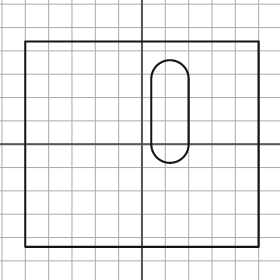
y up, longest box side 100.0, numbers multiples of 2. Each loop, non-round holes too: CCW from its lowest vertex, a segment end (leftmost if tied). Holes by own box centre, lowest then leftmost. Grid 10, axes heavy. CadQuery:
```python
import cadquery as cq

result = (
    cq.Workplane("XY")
    .moveTo(-50.0, -44.0)
    .lineTo(50.0, -44.0)
    .lineTo(50.0, 44.0)
    .lineTo(-50.0, 44.0)
    .close()
    .moveTo(4.0, 0.0)
    .threePointArc((12.0, -8.0), (20.0, 0.0))
    .lineTo(20.0, 28.0)
    .threePointArc((12.0, 36.0), (4.0, 28.0))
    .close()
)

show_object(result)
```